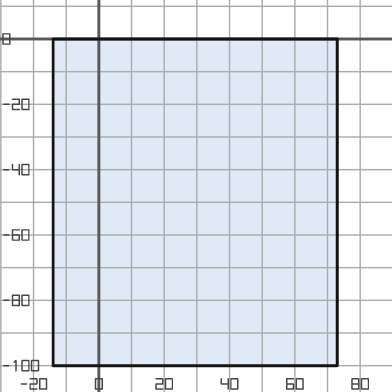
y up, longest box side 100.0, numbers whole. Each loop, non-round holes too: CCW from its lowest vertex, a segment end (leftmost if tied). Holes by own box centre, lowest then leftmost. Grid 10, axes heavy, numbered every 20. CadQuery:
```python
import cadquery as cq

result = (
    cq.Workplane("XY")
    .moveTo(-14.0, -100.0)
    .lineTo(73.0, -100.0)
    .lineTo(73.0, 0.0)
    .lineTo(-14.0, 0.0)
    .close()
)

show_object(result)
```